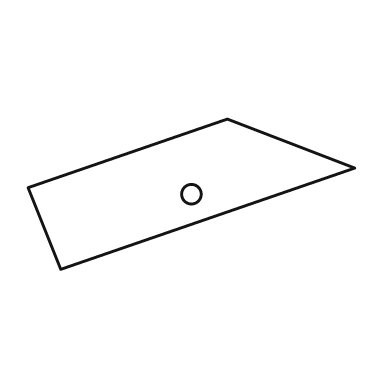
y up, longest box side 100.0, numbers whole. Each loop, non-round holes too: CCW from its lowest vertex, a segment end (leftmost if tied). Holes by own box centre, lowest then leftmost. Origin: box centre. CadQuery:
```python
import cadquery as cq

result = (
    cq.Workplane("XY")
    .moveTo(-40.0, -23.0)
    .lineTo(50.0, 8.0)
    .lineTo(11.0, 23.0)
    .lineTo(-50.0, 2.0)
    .close()
    .moveTo(0.0, 0.0)
    .circle(3.0)
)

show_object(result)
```